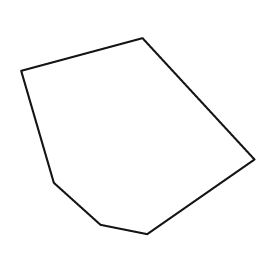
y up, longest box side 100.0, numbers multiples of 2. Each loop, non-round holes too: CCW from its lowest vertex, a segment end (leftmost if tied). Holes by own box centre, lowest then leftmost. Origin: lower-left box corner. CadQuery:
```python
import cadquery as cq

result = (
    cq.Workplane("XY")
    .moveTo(54.0, 0.0)
    .lineTo(100.0, 32.0)
    .lineTo(52.0, 84.0)
    .lineTo(0.0, 70.0)
    .lineTo(14.0, 22.0)
    .lineTo(34.0, 4.0)
    .close()
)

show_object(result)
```